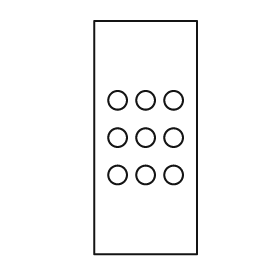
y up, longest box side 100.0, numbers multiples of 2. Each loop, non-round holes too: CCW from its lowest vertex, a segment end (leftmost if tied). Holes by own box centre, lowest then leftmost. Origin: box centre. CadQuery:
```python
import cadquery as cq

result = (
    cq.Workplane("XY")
    .moveTo(-22.0, -50.0)
    .lineTo(22.0, -50.0)
    .lineTo(22.0, 50.0)
    .lineTo(-22.0, 50.0)
    .close()
    .moveTo(-12.0, -16.0)
    .circle(4.0)
    .moveTo(0.0, -16.0)
    .circle(4.0)
    .moveTo(12.0, -16.0)
    .circle(4.0)
    .moveTo(-12.0, 0.0)
    .circle(4.0)
    .moveTo(0.0, 0.0)
    .circle(4.0)
    .moveTo(12.0, 0.0)
    .circle(4.0)
    .moveTo(-12.0, 16.0)
    .circle(4.0)
    .moveTo(0.0, 16.0)
    .circle(4.0)
    .moveTo(12.0, 16.0)
    .circle(4.0)
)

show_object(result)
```